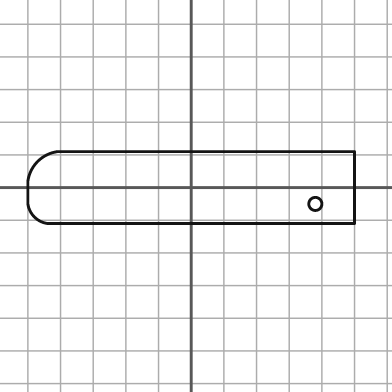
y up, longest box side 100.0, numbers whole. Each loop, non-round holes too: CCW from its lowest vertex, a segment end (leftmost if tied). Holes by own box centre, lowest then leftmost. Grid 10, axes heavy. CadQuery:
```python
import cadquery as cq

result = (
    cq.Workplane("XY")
    .moveTo(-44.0, -11.0)
    .lineTo(50.0, -11.0)
    .lineTo(50.0, 11.0)
    .lineTo(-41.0, 11.0)
    .threePointArc((-47.0, 8.0), (-50.0, 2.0))
    .lineTo(-50.0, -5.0)
    .threePointArc((-48.0, -9.0), (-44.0, -11.0))
    .close()
    .moveTo(38.0, -5.0)
    .circle(2.0)
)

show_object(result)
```